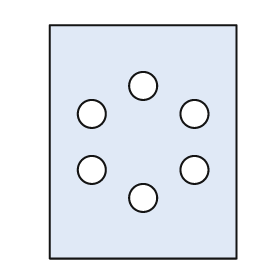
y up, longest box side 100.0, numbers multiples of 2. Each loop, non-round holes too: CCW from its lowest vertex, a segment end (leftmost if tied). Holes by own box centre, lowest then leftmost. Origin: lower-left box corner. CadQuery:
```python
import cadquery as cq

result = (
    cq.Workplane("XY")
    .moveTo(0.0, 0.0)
    .lineTo(80.0, 0.0)
    .lineTo(80.0, 100.0)
    .lineTo(0.0, 100.0)
    .close()
    .moveTo(40.0, 26.0)
    .circle(6.0)
    .moveTo(18.0, 38.0)
    .circle(6.0)
    .moveTo(62.0, 38.0)
    .circle(6.0)
    .moveTo(18.0, 62.0)
    .circle(6.0)
    .moveTo(62.0, 62.0)
    .circle(6.0)
    .moveTo(40.0, 74.0)
    .circle(6.0)
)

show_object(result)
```